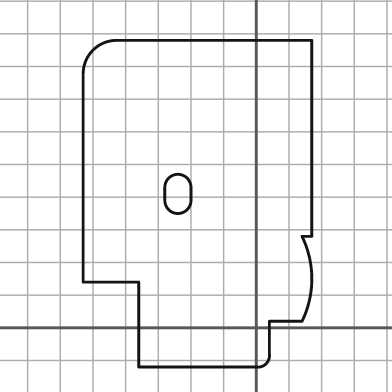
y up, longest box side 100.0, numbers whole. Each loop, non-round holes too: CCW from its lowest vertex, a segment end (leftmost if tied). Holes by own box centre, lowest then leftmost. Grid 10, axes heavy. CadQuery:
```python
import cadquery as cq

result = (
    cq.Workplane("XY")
    .moveTo(-36.0, -12.0)
    .lineTo(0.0, -12.0)
    .threePointArc((3.0, -11.0), (4.0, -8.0))
    .lineTo(4.0, 2.0)
    .lineTo(14.0, 2.0)
    .threePointArc((17.0, 15.0), (14.0, 28.0))
    .lineTo(17.0, 28.0)
    .lineTo(17.0, 88.0)
    .lineTo(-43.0, 88.0)
    .threePointArc((-50.0, 85.0), (-53.0, 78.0))
    .lineTo(-53.0, 14.0)
    .lineTo(-36.0, 14.0)
    .close()
    .moveTo(-28.0, 39.0)
    .threePointArc((-24.0, 35.0), (-20.0, 39.0))
    .lineTo(-20.0, 43.0)
    .threePointArc((-24.0, 47.0), (-28.0, 43.0))
    .close()
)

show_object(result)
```